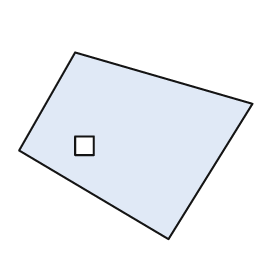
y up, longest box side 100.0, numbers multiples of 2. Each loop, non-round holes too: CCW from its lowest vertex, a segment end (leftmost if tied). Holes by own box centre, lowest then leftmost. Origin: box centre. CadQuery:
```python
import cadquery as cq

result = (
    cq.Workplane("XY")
    .moveTo(14.0, -40.0)
    .lineTo(50.0, 18.0)
    .lineTo(-26.0, 40.0)
    .lineTo(-50.0, -2.0)
    .close()
    .moveTo(-26.0, -4.0)
    .lineTo(-18.0, -4.0)
    .lineTo(-18.0, 4.0)
    .lineTo(-26.0, 4.0)
    .close()
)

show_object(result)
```